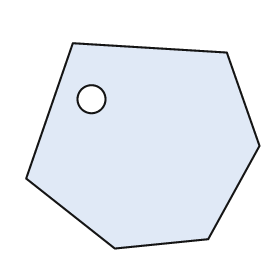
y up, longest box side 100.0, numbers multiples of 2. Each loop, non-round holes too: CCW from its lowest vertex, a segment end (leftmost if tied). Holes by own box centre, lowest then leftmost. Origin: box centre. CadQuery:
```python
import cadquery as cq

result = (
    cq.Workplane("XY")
    .moveTo(-12.0, -44.0)
    .lineTo(28.0, -40.0)
    .lineTo(50.0, 0.0)
    .lineTo(36.0, 40.0)
    .lineTo(-30.0, 44.0)
    .lineTo(-50.0, -14.0)
    .close()
    .moveTo(-22.0, 20.0)
    .circle(6.0)
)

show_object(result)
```